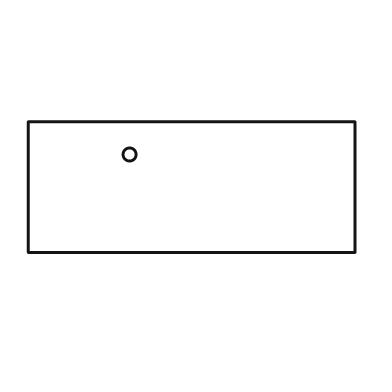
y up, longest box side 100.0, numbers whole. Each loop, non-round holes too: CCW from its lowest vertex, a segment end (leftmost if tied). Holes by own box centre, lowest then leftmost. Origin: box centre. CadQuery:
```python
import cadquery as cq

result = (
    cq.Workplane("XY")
    .moveTo(-50.0, -20.0)
    .lineTo(50.0, -20.0)
    .lineTo(50.0, 20.0)
    .lineTo(-50.0, 20.0)
    .close()
    .moveTo(-19.0, 10.0)
    .circle(2.0)
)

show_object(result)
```